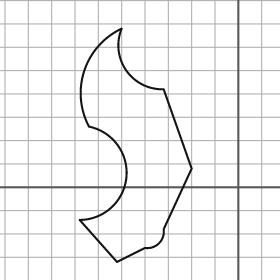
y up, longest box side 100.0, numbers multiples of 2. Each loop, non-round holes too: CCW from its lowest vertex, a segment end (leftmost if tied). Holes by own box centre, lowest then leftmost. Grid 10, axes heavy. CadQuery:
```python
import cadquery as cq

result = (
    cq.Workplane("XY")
    .moveTo(-52.0, -32.0)
    .lineTo(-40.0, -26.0)
    .threePointArc((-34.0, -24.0), (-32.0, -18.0))
    .lineTo(-20.0, 8.0)
    .lineTo(-32.0, 42.0)
    .threePointArc((-48.0, 50.0), (-50.0, 68.0))
    .threePointArc((-66.0, 50.0), (-64.0, 26.0))
    .threePointArc((-48.0, 4.0), (-68.0, -14.0))
    .close()
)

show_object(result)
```